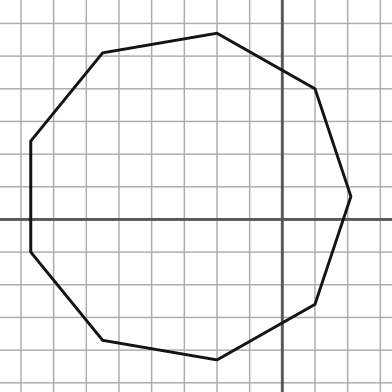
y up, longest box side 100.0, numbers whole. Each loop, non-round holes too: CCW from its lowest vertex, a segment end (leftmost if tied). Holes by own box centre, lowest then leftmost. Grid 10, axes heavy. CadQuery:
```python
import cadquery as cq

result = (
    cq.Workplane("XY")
    .moveTo(-20.0, -43.0)
    .lineTo(10.0, -26.0)
    .lineTo(21.0, 7.0)
    .lineTo(10.0, 40.0)
    .lineTo(-20.0, 57.0)
    .lineTo(-55.0, 51.0)
    .lineTo(-77.0, 24.0)
    .lineTo(-77.0, -10.0)
    .lineTo(-55.0, -37.0)
    .close()
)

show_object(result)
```